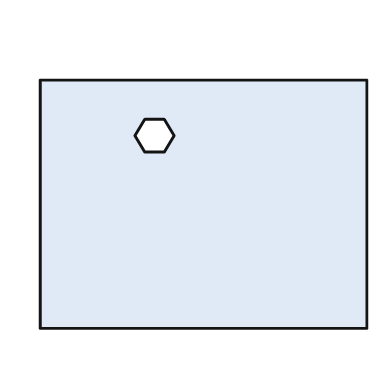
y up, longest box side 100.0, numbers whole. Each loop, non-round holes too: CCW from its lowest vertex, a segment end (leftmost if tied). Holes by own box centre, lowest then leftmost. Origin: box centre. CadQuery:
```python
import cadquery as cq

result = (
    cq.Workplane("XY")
    .moveTo(-50.0, -38.0)
    .lineTo(50.0, -38.0)
    .lineTo(50.0, 38.0)
    .lineTo(-50.0, 38.0)
    .close()
    .moveTo(-18.0, 16.0)
    .lineTo(-12.0, 16.0)
    .lineTo(-9.0, 21.0)
    .lineTo(-12.0, 26.0)
    .lineTo(-18.0, 26.0)
    .lineTo(-21.0, 21.0)
    .close()
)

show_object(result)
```